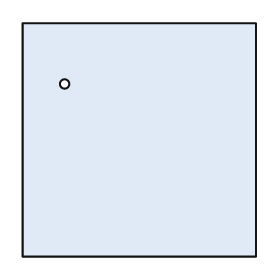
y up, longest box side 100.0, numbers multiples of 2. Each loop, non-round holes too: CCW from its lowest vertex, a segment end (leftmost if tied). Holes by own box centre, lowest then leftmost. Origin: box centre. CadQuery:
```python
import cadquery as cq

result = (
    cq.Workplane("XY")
    .moveTo(-50.0, -50.0)
    .lineTo(50.0, -50.0)
    .lineTo(50.0, 50.0)
    .lineTo(-50.0, 50.0)
    .close()
    .moveTo(-32.0, 24.0)
    .circle(2.0)
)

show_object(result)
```